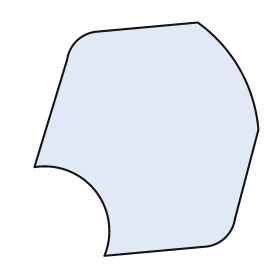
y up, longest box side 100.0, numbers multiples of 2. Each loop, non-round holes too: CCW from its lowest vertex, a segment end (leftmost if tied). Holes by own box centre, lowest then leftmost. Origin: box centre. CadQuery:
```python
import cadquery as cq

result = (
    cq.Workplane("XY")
    .moveTo(-18.0, -50.0)
    .lineTo(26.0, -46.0)
    .threePointArc((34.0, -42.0), (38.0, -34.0))
    .lineTo(48.0, 4.0)
    .threePointArc((40.0, 30.0), (22.0, 50.0))
    .lineTo(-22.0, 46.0)
    .threePointArc((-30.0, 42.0), (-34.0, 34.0))
    .lineTo(-48.0, -12.0)
    .threePointArc((-22.0, -22.0), (-18.0, -50.0))
    .close()
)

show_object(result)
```